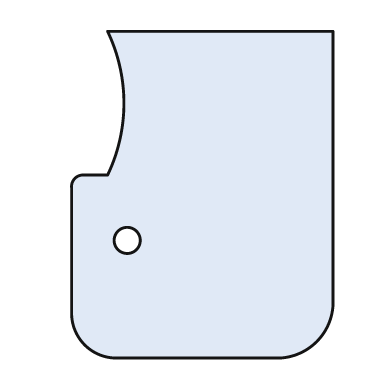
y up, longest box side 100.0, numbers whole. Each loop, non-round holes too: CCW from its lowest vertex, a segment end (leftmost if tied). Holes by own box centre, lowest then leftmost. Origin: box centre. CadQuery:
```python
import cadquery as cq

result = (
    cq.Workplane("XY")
    .moveTo(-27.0, -50.0)
    .lineTo(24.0, -50.0)
    .threePointArc((35.0, -45.0), (40.0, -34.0))
    .lineTo(40.0, 50.0)
    .lineTo(-29.0, 50.0)
    .threePointArc((-24.0, 28.0), (-29.0, 6.0))
    .lineTo(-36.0, 6.0)
    .threePointArc((-39.0, 5.0), (-40.0, 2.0))
    .lineTo(-40.0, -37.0)
    .threePointArc((-36.0, -46.0), (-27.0, -50.0))
    .close()
    .moveTo(-23.0, -14.0)
    .circle(4.0)
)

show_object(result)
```